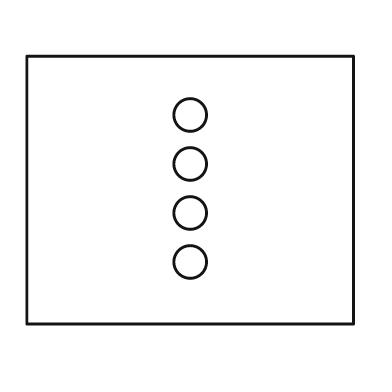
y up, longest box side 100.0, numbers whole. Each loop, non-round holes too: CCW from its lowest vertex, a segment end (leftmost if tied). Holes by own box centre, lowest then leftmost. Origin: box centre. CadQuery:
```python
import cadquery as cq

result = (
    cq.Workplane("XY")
    .moveTo(-50.0, -41.0)
    .lineTo(50.0, -41.0)
    .lineTo(50.0, 41.0)
    .lineTo(-50.0, 41.0)
    .close()
    .moveTo(0.0, -22.0)
    .circle(5.0)
    .moveTo(0.0, -7.0)
    .circle(5.0)
    .moveTo(0.0, 8.0)
    .circle(5.0)
    .moveTo(0.0, 23.0)
    .circle(5.0)
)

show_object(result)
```